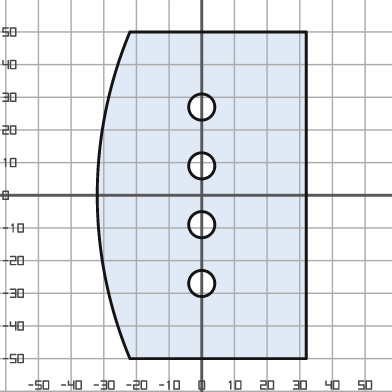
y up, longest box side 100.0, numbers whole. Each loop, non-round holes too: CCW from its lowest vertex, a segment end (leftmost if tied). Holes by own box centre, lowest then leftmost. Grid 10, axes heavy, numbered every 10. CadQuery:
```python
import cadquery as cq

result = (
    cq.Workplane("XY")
    .moveTo(-22.0, -50.0)
    .lineTo(32.0, -50.0)
    .lineTo(32.0, 50.0)
    .lineTo(-22.0, 50.0)
    .threePointArc((-32.0, 0.0), (-22.0, -50.0))
    .close()
    .moveTo(0.0, -27.0)
    .circle(4.0)
    .moveTo(0.0, -9.0)
    .circle(4.0)
    .moveTo(0.0, 9.0)
    .circle(4.0)
    .moveTo(0.0, 27.0)
    .circle(4.0)
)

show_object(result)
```